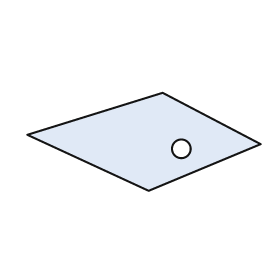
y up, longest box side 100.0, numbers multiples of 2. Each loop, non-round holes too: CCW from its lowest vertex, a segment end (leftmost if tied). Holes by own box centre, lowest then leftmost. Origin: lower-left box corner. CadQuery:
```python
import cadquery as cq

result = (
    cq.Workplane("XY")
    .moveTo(52.0, 0.0)
    .lineTo(100.0, 20.0)
    .lineTo(58.0, 42.0)
    .lineTo(0.0, 24.0)
    .close()
    .moveTo(66.0, 18.0)
    .circle(4.0)
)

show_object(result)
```